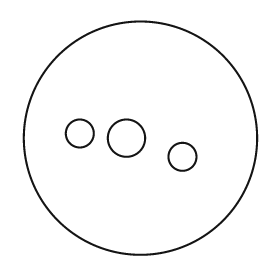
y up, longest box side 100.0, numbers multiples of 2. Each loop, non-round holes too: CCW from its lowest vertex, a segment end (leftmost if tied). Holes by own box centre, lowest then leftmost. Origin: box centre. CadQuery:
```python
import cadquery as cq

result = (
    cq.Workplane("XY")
    .moveTo(0.0, 0.0)
    .circle(50.0)
    .moveTo(18.0, -8.0)
    .circle(6.0)
    .moveTo(-6.0, 0.0)
    .circle(8.0)
    .moveTo(-26.0, 2.0)
    .circle(6.0)
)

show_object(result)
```